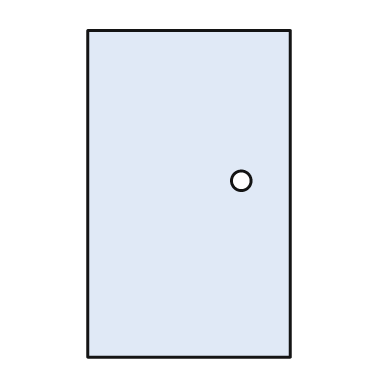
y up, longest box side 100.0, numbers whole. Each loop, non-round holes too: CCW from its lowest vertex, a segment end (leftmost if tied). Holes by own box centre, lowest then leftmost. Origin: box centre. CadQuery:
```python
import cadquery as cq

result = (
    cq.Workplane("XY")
    .moveTo(-31.0, -50.0)
    .lineTo(31.0, -50.0)
    .lineTo(31.0, 50.0)
    .lineTo(-31.0, 50.0)
    .close()
    .moveTo(16.0, 4.0)
    .circle(3.0)
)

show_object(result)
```